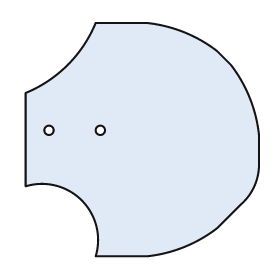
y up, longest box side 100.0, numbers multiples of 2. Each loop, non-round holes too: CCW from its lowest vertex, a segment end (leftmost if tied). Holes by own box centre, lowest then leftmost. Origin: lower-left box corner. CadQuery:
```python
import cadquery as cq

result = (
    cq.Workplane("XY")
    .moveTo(30.0, 0.0)
    .lineTo(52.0, 0.0)
    .threePointArc((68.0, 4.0), (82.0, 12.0))
    .lineTo(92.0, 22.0)
    .threePointArc((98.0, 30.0), (100.0, 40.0))
    .lineTo(100.0, 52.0)
    .threePointArc((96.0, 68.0), (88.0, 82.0))
    .lineTo(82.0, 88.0)
    .threePointArc((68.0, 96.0), (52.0, 100.0))
    .lineTo(30.0, 100.0)
    .threePointArc((18.0, 82.0), (0.0, 70.0))
    .lineTo(0.0, 30.0)
    .threePointArc((24.0, 24.0), (30.0, 0.0))
    .close()
    .moveTo(10.0, 54.0)
    .circle(2.0)
    .moveTo(32.0, 54.0)
    .circle(2.0)
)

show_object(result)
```